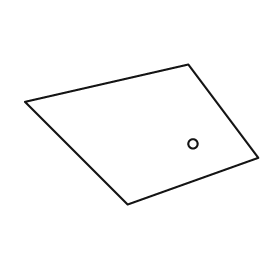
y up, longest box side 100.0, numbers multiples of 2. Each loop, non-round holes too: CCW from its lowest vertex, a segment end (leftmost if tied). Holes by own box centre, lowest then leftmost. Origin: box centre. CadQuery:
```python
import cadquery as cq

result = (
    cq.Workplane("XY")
    .moveTo(-6.0, -30.0)
    .lineTo(50.0, -10.0)
    .lineTo(20.0, 30.0)
    .lineTo(-50.0, 14.0)
    .close()
    .moveTo(22.0, -4.0)
    .circle(2.0)
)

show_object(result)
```